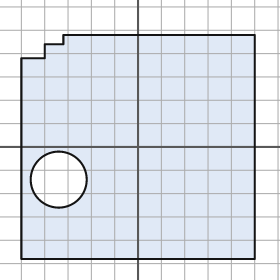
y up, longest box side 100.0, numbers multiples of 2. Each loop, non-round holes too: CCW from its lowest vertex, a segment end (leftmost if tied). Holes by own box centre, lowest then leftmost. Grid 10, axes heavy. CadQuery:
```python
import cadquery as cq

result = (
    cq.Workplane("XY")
    .moveTo(-50.0, -48.0)
    .lineTo(50.0, -48.0)
    .lineTo(50.0, 48.0)
    .lineTo(-32.0, 48.0)
    .lineTo(-32.0, 44.0)
    .lineTo(-40.0, 44.0)
    .lineTo(-40.0, 38.0)
    .lineTo(-50.0, 38.0)
    .close()
    .moveTo(-34.0, -14.0)
    .circle(12.0)
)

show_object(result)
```